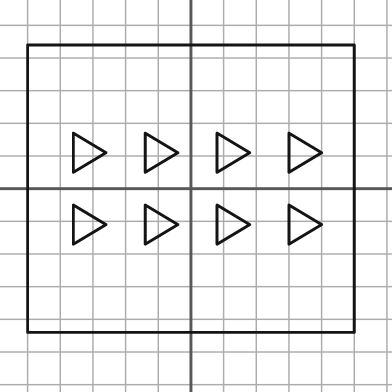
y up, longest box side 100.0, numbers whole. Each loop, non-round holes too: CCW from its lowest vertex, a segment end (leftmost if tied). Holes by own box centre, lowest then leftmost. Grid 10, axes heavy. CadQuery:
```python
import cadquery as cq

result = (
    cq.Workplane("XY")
    .moveTo(-50.0, -44.0)
    .lineTo(50.0, -44.0)
    .lineTo(50.0, 44.0)
    .lineTo(-50.0, 44.0)
    .close()
    .moveTo(-36.0, -17.0)
    .lineTo(-26.0, -11.0)
    .lineTo(-36.0, -5.0)
    .close()
    .moveTo(-14.0, -17.0)
    .lineTo(-4.0, -11.0)
    .lineTo(-14.0, -5.0)
    .close()
    .moveTo(8.0, -17.0)
    .lineTo(18.0, -11.0)
    .lineTo(8.0, -5.0)
    .close()
    .moveTo(30.0, -17.0)
    .lineTo(40.0, -11.0)
    .lineTo(30.0, -5.0)
    .close()
    .moveTo(-36.0, 5.0)
    .lineTo(-26.0, 11.0)
    .lineTo(-36.0, 17.0)
    .close()
    .moveTo(-14.0, 5.0)
    .lineTo(-4.0, 11.0)
    .lineTo(-14.0, 17.0)
    .close()
    .moveTo(8.0, 5.0)
    .lineTo(18.0, 11.0)
    .lineTo(8.0, 17.0)
    .close()
    .moveTo(30.0, 5.0)
    .lineTo(40.0, 11.0)
    .lineTo(30.0, 17.0)
    .close()
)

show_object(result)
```